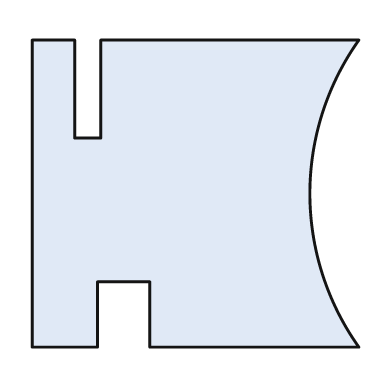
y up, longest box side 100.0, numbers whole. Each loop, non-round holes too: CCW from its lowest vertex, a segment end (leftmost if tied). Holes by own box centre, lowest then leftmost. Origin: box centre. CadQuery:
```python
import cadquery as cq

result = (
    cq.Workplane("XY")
    .moveTo(-50.0, -47.0)
    .lineTo(-30.0, -47.0)
    .lineTo(-30.0, -27.0)
    .lineTo(-14.0, -27.0)
    .lineTo(-14.0, -47.0)
    .lineTo(50.0, -47.0)
    .threePointArc((35.0, 0.0), (50.0, 47.0))
    .lineTo(-29.0, 47.0)
    .lineTo(-29.0, 17.0)
    .lineTo(-37.0, 17.0)
    .lineTo(-37.0, 47.0)
    .lineTo(-50.0, 47.0)
    .close()
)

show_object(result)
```